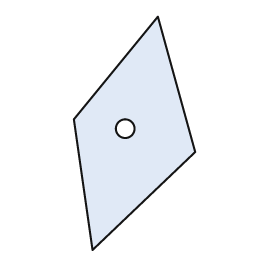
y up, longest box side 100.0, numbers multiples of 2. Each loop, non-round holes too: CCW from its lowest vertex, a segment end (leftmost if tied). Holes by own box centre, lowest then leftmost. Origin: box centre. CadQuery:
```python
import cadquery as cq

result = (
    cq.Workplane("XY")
    .moveTo(-18.0, -50.0)
    .lineTo(26.0, -8.0)
    .lineTo(10.0, 50.0)
    .lineTo(-26.0, 6.0)
    .close()
    .moveTo(-4.0, 2.0)
    .circle(4.0)
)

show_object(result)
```